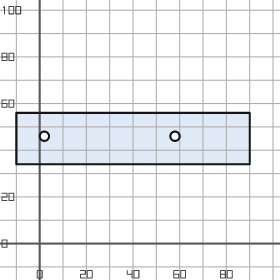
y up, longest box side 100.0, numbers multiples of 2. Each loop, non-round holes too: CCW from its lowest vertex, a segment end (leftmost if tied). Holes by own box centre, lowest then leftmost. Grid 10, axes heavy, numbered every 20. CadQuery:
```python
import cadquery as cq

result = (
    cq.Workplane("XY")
    .moveTo(-10.0, 34.0)
    .lineTo(90.0, 34.0)
    .lineTo(90.0, 56.0)
    .lineTo(-10.0, 56.0)
    .close()
    .moveTo(2.0, 46.0)
    .circle(2.0)
    .moveTo(58.0, 46.0)
    .circle(2.0)
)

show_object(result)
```